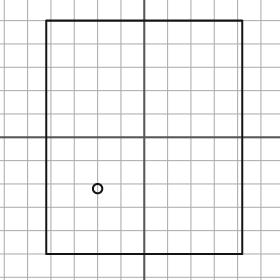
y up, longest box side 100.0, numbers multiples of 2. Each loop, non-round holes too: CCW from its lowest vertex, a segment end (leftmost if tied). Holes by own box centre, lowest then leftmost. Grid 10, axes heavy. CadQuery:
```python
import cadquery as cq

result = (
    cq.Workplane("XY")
    .moveTo(-42.0, -50.0)
    .lineTo(42.0, -50.0)
    .lineTo(42.0, 50.0)
    .lineTo(-42.0, 50.0)
    .close()
    .moveTo(-20.0, -22.0)
    .circle(2.0)
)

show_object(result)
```